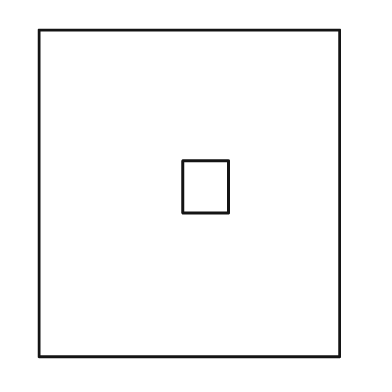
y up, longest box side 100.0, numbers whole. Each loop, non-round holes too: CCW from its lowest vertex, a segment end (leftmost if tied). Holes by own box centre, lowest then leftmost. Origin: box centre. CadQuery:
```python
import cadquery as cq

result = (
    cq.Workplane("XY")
    .moveTo(-46.0, -50.0)
    .lineTo(46.0, -50.0)
    .lineTo(46.0, 50.0)
    .lineTo(-46.0, 50.0)
    .close()
    .moveTo(-2.0, -6.0)
    .lineTo(12.0, -6.0)
    .lineTo(12.0, 10.0)
    .lineTo(-2.0, 10.0)
    .close()
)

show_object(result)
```